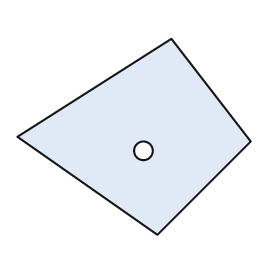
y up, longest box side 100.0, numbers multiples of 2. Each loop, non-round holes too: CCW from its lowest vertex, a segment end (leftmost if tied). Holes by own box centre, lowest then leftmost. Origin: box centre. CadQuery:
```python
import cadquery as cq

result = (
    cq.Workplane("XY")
    .moveTo(10.0, -42.0)
    .lineTo(50.0, -2.0)
    .lineTo(16.0, 42.0)
    .lineTo(-50.0, 0.0)
    .close()
    .moveTo(4.0, -6.0)
    .circle(4.0)
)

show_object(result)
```